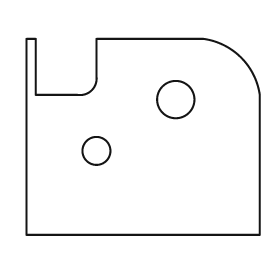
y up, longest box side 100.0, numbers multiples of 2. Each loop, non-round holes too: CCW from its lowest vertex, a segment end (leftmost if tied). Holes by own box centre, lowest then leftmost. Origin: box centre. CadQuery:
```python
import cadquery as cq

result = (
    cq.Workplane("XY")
    .moveTo(-50.0, -42.0)
    .lineTo(50.0, -42.0)
    .lineTo(50.0, 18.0)
    .threePointArc((42.0, 34.0), (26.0, 42.0))
    .lineTo(-20.0, 42.0)
    .lineTo(-20.0, 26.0)
    .threePointArc((-22.0, 20.0), (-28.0, 18.0))
    .lineTo(-46.0, 18.0)
    .lineTo(-46.0, 42.0)
    .lineTo(-50.0, 42.0)
    .close()
    .moveTo(-20.0, -6.0)
    .circle(6.0)
    .moveTo(14.0, 16.0)
    .circle(8.0)
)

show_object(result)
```